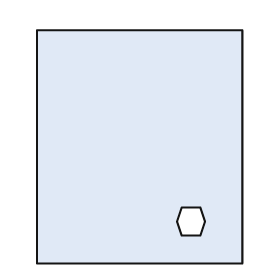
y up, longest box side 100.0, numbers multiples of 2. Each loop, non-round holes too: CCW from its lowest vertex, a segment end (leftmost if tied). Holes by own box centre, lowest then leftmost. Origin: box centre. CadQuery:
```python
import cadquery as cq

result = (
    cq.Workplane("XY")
    .moveTo(-44.0, -50.0)
    .lineTo(44.0, -50.0)
    .lineTo(44.0, 50.0)
    .lineTo(-44.0, 50.0)
    .close()
    .moveTo(18.0, -38.0)
    .lineTo(26.0, -38.0)
    .lineTo(28.0, -32.0)
    .lineTo(26.0, -26.0)
    .lineTo(18.0, -26.0)
    .lineTo(16.0, -32.0)
    .close()
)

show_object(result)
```